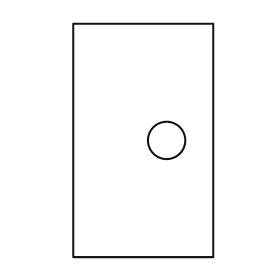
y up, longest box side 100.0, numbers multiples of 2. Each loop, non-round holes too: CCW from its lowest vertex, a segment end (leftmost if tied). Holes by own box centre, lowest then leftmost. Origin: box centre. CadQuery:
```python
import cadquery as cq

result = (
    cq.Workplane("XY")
    .moveTo(-30.0, -50.0)
    .lineTo(30.0, -50.0)
    .lineTo(30.0, 50.0)
    .lineTo(-30.0, 50.0)
    .close()
    .moveTo(10.0, 0.0)
    .circle(8.0)
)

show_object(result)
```